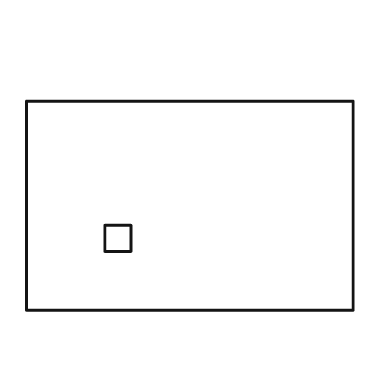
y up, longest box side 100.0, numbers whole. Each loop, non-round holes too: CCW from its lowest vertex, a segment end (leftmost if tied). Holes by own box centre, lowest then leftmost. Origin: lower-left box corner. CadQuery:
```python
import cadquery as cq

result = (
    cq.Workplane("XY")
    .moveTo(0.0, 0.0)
    .lineTo(100.0, 0.0)
    .lineTo(100.0, 64.0)
    .lineTo(0.0, 64.0)
    .close()
    .moveTo(24.0, 18.0)
    .lineTo(32.0, 18.0)
    .lineTo(32.0, 26.0)
    .lineTo(24.0, 26.0)
    .close()
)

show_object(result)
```